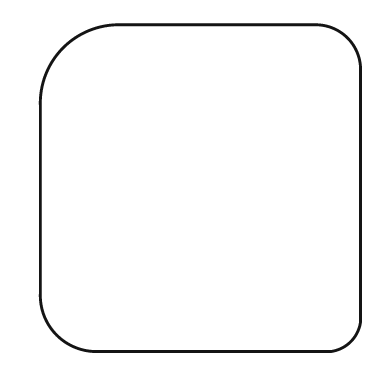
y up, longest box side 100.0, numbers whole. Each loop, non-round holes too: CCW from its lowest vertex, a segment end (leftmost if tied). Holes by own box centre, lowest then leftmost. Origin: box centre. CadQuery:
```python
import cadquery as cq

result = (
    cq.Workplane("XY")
    .moveTo(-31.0, -50.0)
    .lineTo(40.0, -50.0)
    .threePointArc((46.0, -47.0), (49.0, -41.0))
    .lineTo(49.0, 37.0)
    .threePointArc((45.0, 46.0), (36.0, 50.0))
    .lineTo(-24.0, 50.0)
    .threePointArc((-42.0, 43.0), (-49.0, 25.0))
    .lineTo(-49.0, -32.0)
    .threePointArc((-44.0, -45.0), (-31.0, -50.0))
    .close()
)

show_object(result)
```